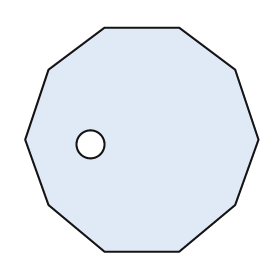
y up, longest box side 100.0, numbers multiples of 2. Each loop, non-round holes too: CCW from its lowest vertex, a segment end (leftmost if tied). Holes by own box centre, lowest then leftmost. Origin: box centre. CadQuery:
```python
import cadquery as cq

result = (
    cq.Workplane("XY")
    .moveTo(-16.0, -48.0)
    .lineTo(16.0, -48.0)
    .lineTo(40.0, -28.0)
    .lineTo(50.0, 0.0)
    .lineTo(40.0, 30.0)
    .lineTo(16.0, 48.0)
    .lineTo(-16.0, 48.0)
    .lineTo(-40.0, 30.0)
    .lineTo(-50.0, 0.0)
    .lineTo(-40.0, -28.0)
    .close()
    .moveTo(-22.0, -2.0)
    .circle(6.0)
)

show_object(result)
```